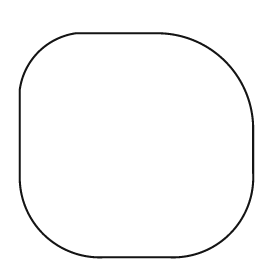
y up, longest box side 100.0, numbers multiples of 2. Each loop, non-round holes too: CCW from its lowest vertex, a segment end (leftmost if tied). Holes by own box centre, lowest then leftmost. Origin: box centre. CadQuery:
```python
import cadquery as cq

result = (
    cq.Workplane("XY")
    .moveTo(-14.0, -48.0)
    .lineTo(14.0, -48.0)
    .threePointArc((40.0, -38.0), (50.0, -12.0))
    .lineTo(50.0, 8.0)
    .threePointArc((38.0, 36.0), (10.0, 48.0))
    .lineTo(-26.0, 48.0)
    .threePointArc((-42.0, 40.0), (-50.0, 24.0))
    .lineTo(-50.0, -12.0)
    .threePointArc((-40.0, -38.0), (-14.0, -48.0))
    .close()
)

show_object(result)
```